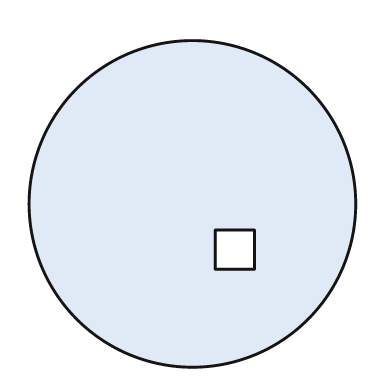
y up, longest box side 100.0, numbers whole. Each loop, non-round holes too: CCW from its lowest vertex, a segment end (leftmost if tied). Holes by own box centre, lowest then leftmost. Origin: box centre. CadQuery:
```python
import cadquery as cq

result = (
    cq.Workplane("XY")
    .moveTo(0.0, 0.0)
    .circle(50.0)
    .moveTo(7.0, -20.0)
    .lineTo(19.0, -20.0)
    .lineTo(19.0, -8.0)
    .lineTo(7.0, -8.0)
    .close()
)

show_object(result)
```